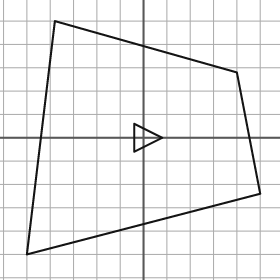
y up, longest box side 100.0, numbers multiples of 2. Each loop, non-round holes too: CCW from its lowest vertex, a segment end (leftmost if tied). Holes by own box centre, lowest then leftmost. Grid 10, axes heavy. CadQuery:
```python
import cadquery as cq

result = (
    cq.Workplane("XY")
    .moveTo(-50.0, -50.0)
    .lineTo(50.0, -24.0)
    .lineTo(40.0, 28.0)
    .lineTo(-38.0, 50.0)
    .close()
    .moveTo(-4.0, -6.0)
    .lineTo(8.0, 0.0)
    .lineTo(-4.0, 6.0)
    .close()
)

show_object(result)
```